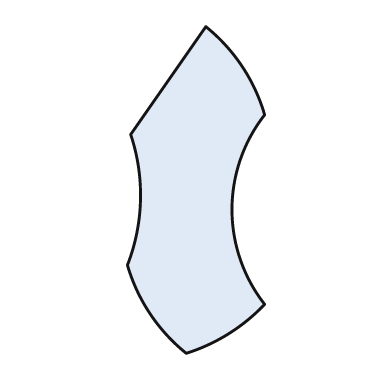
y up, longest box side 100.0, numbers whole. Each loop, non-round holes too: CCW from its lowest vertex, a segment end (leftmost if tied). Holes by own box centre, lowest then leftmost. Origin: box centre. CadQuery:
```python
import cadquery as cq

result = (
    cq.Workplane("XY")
    .moveTo(-3.0, -50.0)
    .threePointArc((10.0, -44.0), (21.0, -35.0))
    .threePointArc((11.0, -6.0), (21.0, 23.0))
    .threePointArc((14.0, 38.0), (3.0, 50.0))
    .lineTo(-20.0, 17.0)
    .threePointArc((-17.0, -3.0), (-21.0, -23.0))
    .threePointArc((-14.0, -38.0), (-3.0, -50.0))
    .close()
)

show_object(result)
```